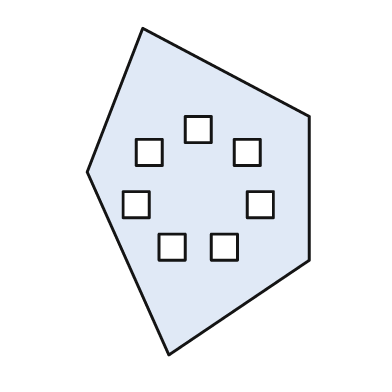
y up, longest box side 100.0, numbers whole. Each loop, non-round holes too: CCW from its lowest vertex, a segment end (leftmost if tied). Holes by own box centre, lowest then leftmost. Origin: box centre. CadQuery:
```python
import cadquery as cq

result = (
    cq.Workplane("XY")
    .moveTo(-9.0, -50.0)
    .lineTo(34.0, -21.0)
    .lineTo(34.0, 23.0)
    .lineTo(-17.0, 50.0)
    .lineTo(-34.0, 6.0)
    .close()
    .moveTo(-12.0, -21.0)
    .lineTo(-4.0, -21.0)
    .lineTo(-4.0, -13.0)
    .lineTo(-12.0, -13.0)
    .close()
    .moveTo(4.0, -21.0)
    .lineTo(12.0, -21.0)
    .lineTo(12.0, -13.0)
    .lineTo(4.0, -13.0)
    .close()
    .moveTo(-23.0, -8.0)
    .lineTo(-15.0, -8.0)
    .lineTo(-15.0, 0.0)
    .lineTo(-23.0, 0.0)
    .close()
    .moveTo(15.0, -8.0)
    .lineTo(23.0, -8.0)
    .lineTo(23.0, 0.0)
    .lineTo(15.0, 0.0)
    .close()
    .moveTo(-19.0, 8.0)
    .lineTo(-11.0, 8.0)
    .lineTo(-11.0, 16.0)
    .lineTo(-19.0, 16.0)
    .close()
    .moveTo(11.0, 8.0)
    .lineTo(19.0, 8.0)
    .lineTo(19.0, 16.0)
    .lineTo(11.0, 16.0)
    .close()
    .moveTo(-4.0, 15.0)
    .lineTo(4.0, 15.0)
    .lineTo(4.0, 23.0)
    .lineTo(-4.0, 23.0)
    .close()
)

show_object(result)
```